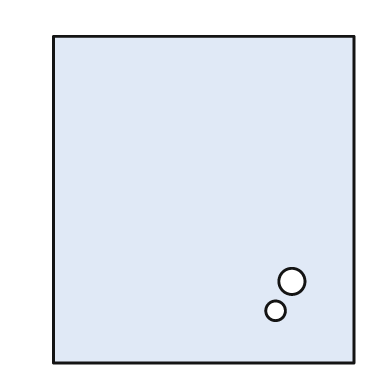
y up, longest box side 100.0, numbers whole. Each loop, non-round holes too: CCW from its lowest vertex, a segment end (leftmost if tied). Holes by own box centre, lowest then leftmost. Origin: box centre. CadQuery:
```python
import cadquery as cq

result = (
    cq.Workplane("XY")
    .moveTo(-46.0, -50.0)
    .lineTo(46.0, -50.0)
    .lineTo(46.0, 50.0)
    .lineTo(-46.0, 50.0)
    .close()
    .moveTo(22.0, -34.0)
    .circle(3.0)
    .moveTo(27.0, -25.0)
    .circle(4.0)
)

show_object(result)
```